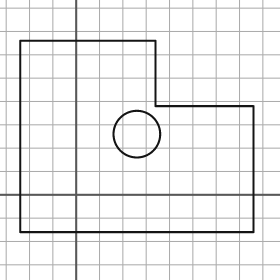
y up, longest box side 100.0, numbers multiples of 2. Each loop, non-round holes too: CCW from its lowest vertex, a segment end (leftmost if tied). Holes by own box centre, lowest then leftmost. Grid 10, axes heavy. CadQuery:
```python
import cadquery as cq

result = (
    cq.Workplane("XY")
    .moveTo(-24.0, -16.0)
    .lineTo(76.0, -16.0)
    .lineTo(76.0, 38.0)
    .lineTo(34.0, 38.0)
    .lineTo(34.0, 66.0)
    .lineTo(-24.0, 66.0)
    .close()
    .moveTo(26.0, 26.0)
    .circle(10.0)
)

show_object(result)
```